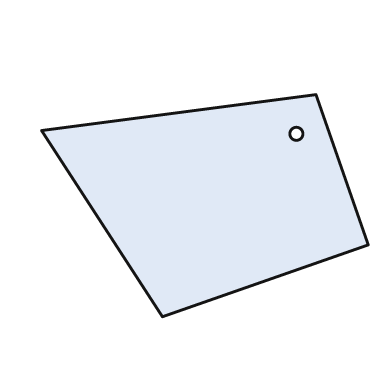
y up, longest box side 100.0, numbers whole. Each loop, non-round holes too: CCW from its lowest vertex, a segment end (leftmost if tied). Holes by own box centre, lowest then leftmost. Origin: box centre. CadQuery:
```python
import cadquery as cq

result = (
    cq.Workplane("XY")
    .moveTo(-13.0, -34.0)
    .lineTo(50.0, -12.0)
    .lineTo(34.0, 34.0)
    .lineTo(-50.0, 23.0)
    .close()
    .moveTo(28.0, 22.0)
    .circle(2.0)
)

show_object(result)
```